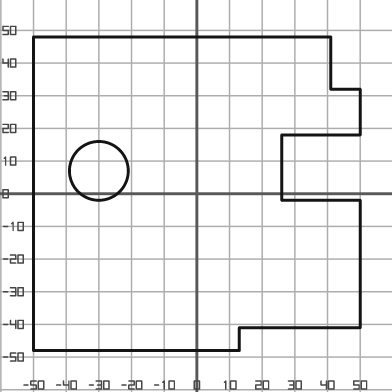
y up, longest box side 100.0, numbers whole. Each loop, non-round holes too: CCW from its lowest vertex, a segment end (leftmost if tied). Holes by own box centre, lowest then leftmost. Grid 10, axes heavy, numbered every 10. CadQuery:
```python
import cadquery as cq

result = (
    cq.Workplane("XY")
    .moveTo(-50.0, -48.0)
    .lineTo(13.0, -48.0)
    .lineTo(13.0, -41.0)
    .lineTo(50.0, -41.0)
    .lineTo(50.0, -2.0)
    .lineTo(26.0, -2.0)
    .lineTo(26.0, 18.0)
    .lineTo(50.0, 18.0)
    .lineTo(50.0, 32.0)
    .lineTo(41.0, 32.0)
    .lineTo(41.0, 48.0)
    .lineTo(-50.0, 48.0)
    .close()
    .moveTo(-30.0, 7.0)
    .circle(9.0)
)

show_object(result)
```